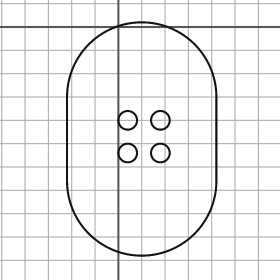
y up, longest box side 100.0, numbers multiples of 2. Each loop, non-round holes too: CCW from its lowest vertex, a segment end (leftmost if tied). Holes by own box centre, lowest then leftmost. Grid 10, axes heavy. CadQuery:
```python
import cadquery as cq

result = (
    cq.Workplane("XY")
    .moveTo(-22.0, -66.0)
    .threePointArc((10.0, -98.0), (42.0, -66.0))
    .lineTo(42.0, -30.0)
    .threePointArc((10.0, 2.0), (-22.0, -30.0))
    .close()
    .moveTo(4.0, -54.0)
    .circle(4.0)
    .moveTo(18.0, -54.0)
    .circle(4.0)
    .moveTo(4.0, -40.0)
    .circle(4.0)
    .moveTo(18.0, -40.0)
    .circle(4.0)
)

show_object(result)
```